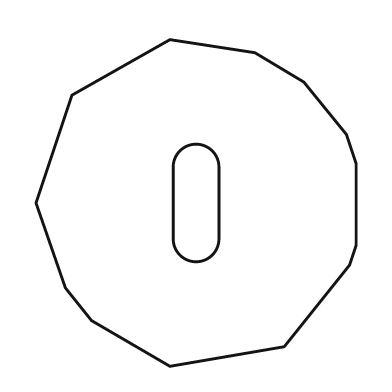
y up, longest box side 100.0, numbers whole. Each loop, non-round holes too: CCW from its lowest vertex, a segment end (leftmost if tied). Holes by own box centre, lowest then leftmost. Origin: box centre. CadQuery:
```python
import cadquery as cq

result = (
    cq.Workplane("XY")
    .moveTo(-8.0, -50.0)
    .lineTo(27.0, -44.0)
    .lineTo(47.0, -19.0)
    .lineTo(49.0, -13.0)
    .lineTo(49.0, 12.0)
    .lineTo(46.0, 21.0)
    .lineTo(33.0, 37.0)
    .lineTo(18.0, 46.0)
    .lineTo(-8.0, 50.0)
    .lineTo(-38.0, 33.0)
    .lineTo(-49.0, 0.0)
    .lineTo(-40.0, -26.0)
    .lineTo(-32.0, -36.0)
    .close()
    .moveTo(-7.0, -11.0)
    .threePointArc((0.0, -18.0), (7.0, -11.0))
    .lineTo(7.0, 11.0)
    .threePointArc((0.0, 18.0), (-7.0, 11.0))
    .close()
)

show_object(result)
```